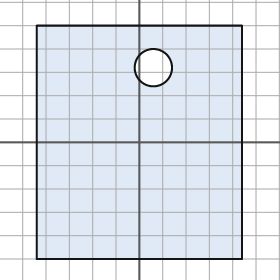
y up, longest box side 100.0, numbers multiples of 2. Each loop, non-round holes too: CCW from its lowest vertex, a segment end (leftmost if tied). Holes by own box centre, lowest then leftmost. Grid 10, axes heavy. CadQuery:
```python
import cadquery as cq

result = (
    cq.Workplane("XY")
    .moveTo(-44.0, -50.0)
    .lineTo(44.0, -50.0)
    .lineTo(44.0, 50.0)
    .lineTo(-44.0, 50.0)
    .close()
    .moveTo(6.0, 32.0)
    .circle(8.0)
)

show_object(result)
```